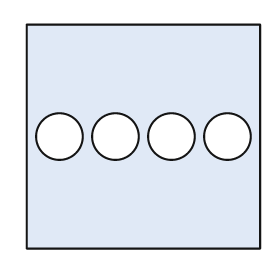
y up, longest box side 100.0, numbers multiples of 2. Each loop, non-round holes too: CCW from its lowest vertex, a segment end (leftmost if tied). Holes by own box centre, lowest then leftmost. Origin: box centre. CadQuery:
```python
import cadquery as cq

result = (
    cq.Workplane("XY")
    .moveTo(-50.0, -48.0)
    .lineTo(50.0, -48.0)
    .lineTo(50.0, 48.0)
    .lineTo(-50.0, 48.0)
    .close()
    .moveTo(-36.0, 0.0)
    .circle(10.0)
    .moveTo(-12.0, 0.0)
    .circle(10.0)
    .moveTo(12.0, 0.0)
    .circle(10.0)
    .moveTo(36.0, 0.0)
    .circle(10.0)
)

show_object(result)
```